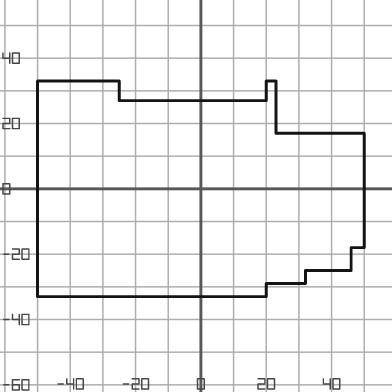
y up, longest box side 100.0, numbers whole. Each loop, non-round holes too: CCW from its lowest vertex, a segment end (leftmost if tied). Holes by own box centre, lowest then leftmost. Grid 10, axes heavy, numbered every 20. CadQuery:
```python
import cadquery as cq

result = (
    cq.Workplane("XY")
    .moveTo(-50.0, -33.0)
    .lineTo(20.0, -33.0)
    .lineTo(20.0, -29.0)
    .lineTo(32.0, -29.0)
    .lineTo(32.0, -25.0)
    .lineTo(46.0, -25.0)
    .lineTo(46.0, -18.0)
    .lineTo(50.0, -18.0)
    .lineTo(50.0, 17.0)
    .lineTo(23.0, 17.0)
    .lineTo(23.0, 33.0)
    .lineTo(20.0, 33.0)
    .lineTo(20.0, 27.0)
    .lineTo(-25.0, 27.0)
    .lineTo(-25.0, 33.0)
    .lineTo(-50.0, 33.0)
    .close()
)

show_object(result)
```